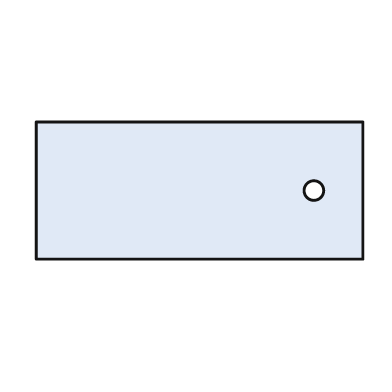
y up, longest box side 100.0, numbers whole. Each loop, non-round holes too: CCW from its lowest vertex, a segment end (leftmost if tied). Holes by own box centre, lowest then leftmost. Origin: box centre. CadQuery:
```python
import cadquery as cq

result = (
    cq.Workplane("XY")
    .moveTo(-50.0, -21.0)
    .lineTo(50.0, -21.0)
    .lineTo(50.0, 21.0)
    .lineTo(-50.0, 21.0)
    .close()
    .moveTo(35.0, 0.0)
    .circle(3.0)
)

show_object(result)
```